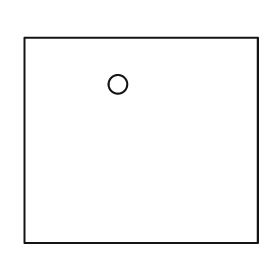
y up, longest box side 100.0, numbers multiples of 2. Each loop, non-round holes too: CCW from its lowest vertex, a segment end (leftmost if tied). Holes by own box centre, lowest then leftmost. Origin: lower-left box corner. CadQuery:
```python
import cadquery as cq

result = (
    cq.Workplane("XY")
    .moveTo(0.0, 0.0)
    .lineTo(100.0, 0.0)
    .lineTo(100.0, 88.0)
    .lineTo(0.0, 88.0)
    .close()
    .moveTo(40.0, 68.0)
    .circle(4.0)
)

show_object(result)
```